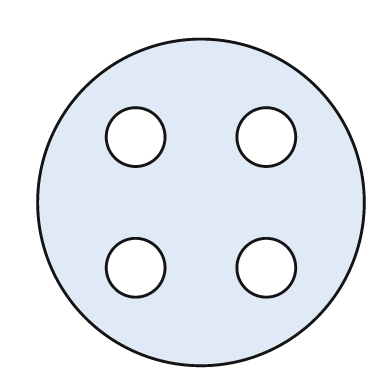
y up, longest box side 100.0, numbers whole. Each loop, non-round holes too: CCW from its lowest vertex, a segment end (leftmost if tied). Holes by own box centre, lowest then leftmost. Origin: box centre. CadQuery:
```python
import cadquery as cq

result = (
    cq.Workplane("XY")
    .moveTo(0.0, 0.0)
    .circle(50.0)
    .moveTo(-20.0, -20.0)
    .circle(9.0)
    .moveTo(20.0, -20.0)
    .circle(9.0)
    .moveTo(-20.0, 20.0)
    .circle(9.0)
    .moveTo(20.0, 20.0)
    .circle(9.0)
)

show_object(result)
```